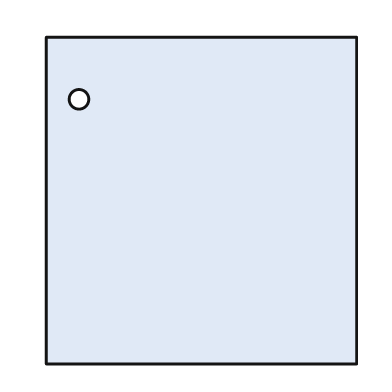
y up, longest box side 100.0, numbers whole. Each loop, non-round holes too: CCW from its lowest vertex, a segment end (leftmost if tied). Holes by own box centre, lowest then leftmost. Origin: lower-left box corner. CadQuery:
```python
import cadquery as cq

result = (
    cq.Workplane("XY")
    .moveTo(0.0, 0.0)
    .lineTo(95.0, 0.0)
    .lineTo(95.0, 100.0)
    .lineTo(0.0, 100.0)
    .close()
    .moveTo(10.0, 81.0)
    .circle(3.0)
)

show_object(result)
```